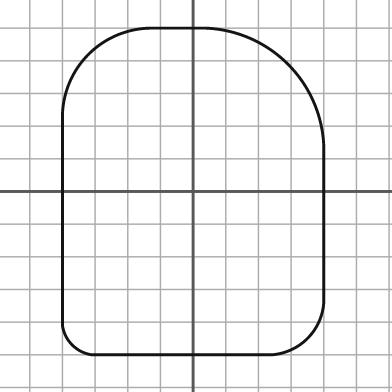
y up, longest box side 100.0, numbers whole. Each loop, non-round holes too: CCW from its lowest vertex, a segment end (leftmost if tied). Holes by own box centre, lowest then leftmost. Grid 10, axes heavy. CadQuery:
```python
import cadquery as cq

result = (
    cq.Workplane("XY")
    .moveTo(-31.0, -50.0)
    .lineTo(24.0, -50.0)
    .threePointArc((35.0, -45.0), (40.0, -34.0))
    .lineTo(40.0, 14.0)
    .threePointArc((29.0, 39.0), (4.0, 50.0))
    .lineTo(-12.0, 50.0)
    .threePointArc((-32.0, 42.0), (-40.0, 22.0))
    .lineTo(-40.0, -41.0)
    .threePointArc((-37.0, -47.0), (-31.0, -50.0))
    .close()
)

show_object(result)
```